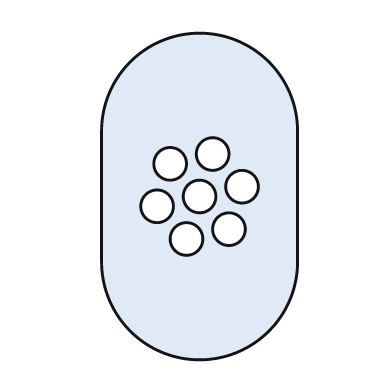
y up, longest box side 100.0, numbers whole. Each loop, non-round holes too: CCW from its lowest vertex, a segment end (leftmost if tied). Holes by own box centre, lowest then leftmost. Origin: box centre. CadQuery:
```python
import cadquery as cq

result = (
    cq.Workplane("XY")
    .moveTo(-30.0, -20.0)
    .threePointArc((0.0, -50.0), (30.0, -20.0))
    .lineTo(30.0, 20.0)
    .threePointArc((0.0, 50.0), (-30.0, 20.0))
    .close()
    .moveTo(-4.0, -13.0)
    .circle(5.0)
    .moveTo(9.0, -10.0)
    .circle(5.0)
    .moveTo(-13.0, -3.0)
    .circle(5.0)
    .moveTo(0.0, 0.0)
    .circle(5.0)
    .moveTo(13.0, 3.0)
    .circle(5.0)
    .moveTo(-9.0, 10.0)
    .circle(5.0)
    .moveTo(4.0, 13.0)
    .circle(5.0)
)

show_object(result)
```